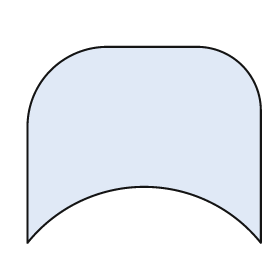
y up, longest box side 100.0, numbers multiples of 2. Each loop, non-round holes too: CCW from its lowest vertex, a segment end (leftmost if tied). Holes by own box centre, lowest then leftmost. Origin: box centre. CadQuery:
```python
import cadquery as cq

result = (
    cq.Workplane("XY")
    .moveTo(-50.0, -42.0)
    .threePointArc((0.0, -18.0), (50.0, -42.0))
    .lineTo(50.0, 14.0)
    .threePointArc((42.0, 34.0), (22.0, 42.0))
    .lineTo(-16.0, 42.0)
    .threePointArc((-40.0, 32.0), (-50.0, 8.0))
    .close()
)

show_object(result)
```